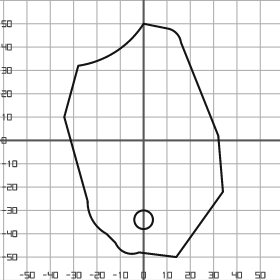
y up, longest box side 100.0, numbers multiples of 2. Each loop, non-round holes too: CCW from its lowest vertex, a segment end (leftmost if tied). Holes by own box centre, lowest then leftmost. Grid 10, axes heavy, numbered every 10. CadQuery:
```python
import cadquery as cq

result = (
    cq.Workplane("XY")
    .moveTo(14.0, -50.0)
    .lineTo(34.0, -22.0)
    .lineTo(32.0, 2.0)
    .lineTo(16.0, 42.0)
    .threePointArc((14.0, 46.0), (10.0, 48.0))
    .lineTo(0.0, 50.0)
    .threePointArc((-12.0, 38.0), (-28.0, 32.0))
    .lineTo(-34.0, 10.0)
    .lineTo(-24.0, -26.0)
    .threePointArc((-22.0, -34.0), (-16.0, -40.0))
    .lineTo(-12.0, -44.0)
    .threePointArc((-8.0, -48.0), (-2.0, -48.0))
    .close()
    .moveTo(0.0, -34.0)
    .circle(4.0)
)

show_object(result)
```